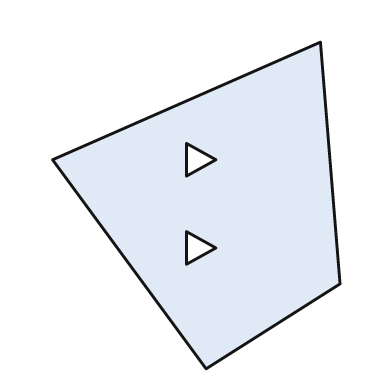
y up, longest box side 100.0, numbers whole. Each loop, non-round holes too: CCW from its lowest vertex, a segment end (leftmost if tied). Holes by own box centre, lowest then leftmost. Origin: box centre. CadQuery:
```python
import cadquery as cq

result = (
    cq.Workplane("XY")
    .moveTo(3.0, -50.0)
    .lineTo(44.0, -24.0)
    .lineTo(38.0, 50.0)
    .lineTo(-44.0, 14.0)
    .close()
    .moveTo(-3.0, -18.0)
    .lineTo(6.0, -13.0)
    .lineTo(-3.0, -8.0)
    .close()
    .moveTo(-3.0, 9.0)
    .lineTo(6.0, 14.0)
    .lineTo(-3.0, 19.0)
    .close()
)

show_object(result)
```